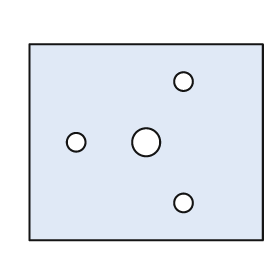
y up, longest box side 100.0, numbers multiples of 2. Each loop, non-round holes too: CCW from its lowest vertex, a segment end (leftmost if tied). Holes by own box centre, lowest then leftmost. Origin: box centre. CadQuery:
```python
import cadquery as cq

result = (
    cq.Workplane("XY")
    .moveTo(-50.0, -42.0)
    .lineTo(50.0, -42.0)
    .lineTo(50.0, 42.0)
    .lineTo(-50.0, 42.0)
    .close()
    .moveTo(16.0, -26.0)
    .circle(4.0)
    .moveTo(-30.0, 0.0)
    .circle(4.0)
    .moveTo(0.0, 0.0)
    .circle(6.0)
    .moveTo(16.0, 26.0)
    .circle(4.0)
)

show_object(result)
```